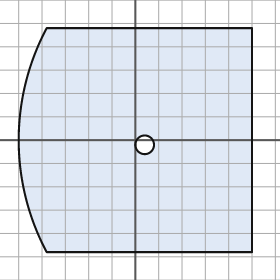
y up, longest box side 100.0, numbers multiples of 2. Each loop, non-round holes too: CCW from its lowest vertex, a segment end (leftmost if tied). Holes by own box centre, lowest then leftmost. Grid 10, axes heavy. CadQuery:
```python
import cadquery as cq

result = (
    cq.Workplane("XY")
    .moveTo(-38.0, -48.0)
    .lineTo(50.0, -48.0)
    .lineTo(50.0, 48.0)
    .lineTo(-38.0, 48.0)
    .threePointArc((-50.0, 0.0), (-38.0, -48.0))
    .close()
    .moveTo(4.0, -2.0)
    .circle(4.0)
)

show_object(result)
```